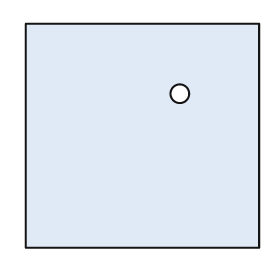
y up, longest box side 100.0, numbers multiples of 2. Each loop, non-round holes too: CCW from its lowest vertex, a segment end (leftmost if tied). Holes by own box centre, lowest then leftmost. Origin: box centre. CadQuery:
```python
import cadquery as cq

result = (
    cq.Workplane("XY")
    .moveTo(-50.0, -48.0)
    .lineTo(50.0, -48.0)
    .lineTo(50.0, 48.0)
    .lineTo(-50.0, 48.0)
    .close()
    .moveTo(16.0, 18.0)
    .circle(4.0)
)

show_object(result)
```